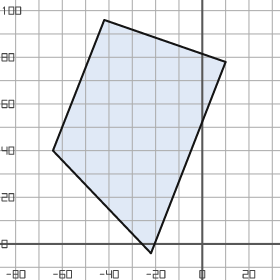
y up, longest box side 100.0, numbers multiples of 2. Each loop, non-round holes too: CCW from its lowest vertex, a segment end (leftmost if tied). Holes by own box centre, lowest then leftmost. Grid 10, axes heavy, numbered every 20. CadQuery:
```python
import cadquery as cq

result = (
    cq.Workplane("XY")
    .moveTo(-22.0, -4.0)
    .lineTo(10.0, 78.0)
    .lineTo(-42.0, 96.0)
    .lineTo(-64.0, 40.0)
    .close()
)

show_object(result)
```